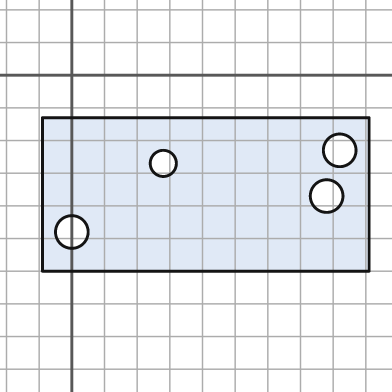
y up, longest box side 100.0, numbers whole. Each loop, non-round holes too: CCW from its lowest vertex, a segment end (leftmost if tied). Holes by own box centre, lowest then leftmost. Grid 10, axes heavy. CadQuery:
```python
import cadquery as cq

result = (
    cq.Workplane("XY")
    .moveTo(-9.0, -60.0)
    .lineTo(91.0, -60.0)
    .lineTo(91.0, -13.0)
    .lineTo(-9.0, -13.0)
    .close()
    .moveTo(0.0, -48.0)
    .circle(5.0)
    .moveTo(78.0, -37.0)
    .circle(5.0)
    .moveTo(28.0, -27.0)
    .circle(4.0)
    .moveTo(82.0, -23.0)
    .circle(5.0)
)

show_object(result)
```